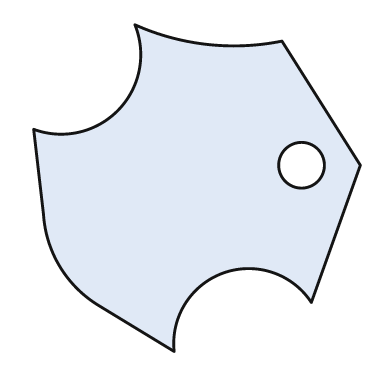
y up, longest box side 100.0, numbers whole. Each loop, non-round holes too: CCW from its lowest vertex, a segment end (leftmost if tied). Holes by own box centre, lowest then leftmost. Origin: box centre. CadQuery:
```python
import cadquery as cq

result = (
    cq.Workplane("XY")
    .moveTo(-7.0, -50.0)
    .threePointArc((8.0, -26.0), (35.0, -35.0))
    .lineTo(50.0, 7.0)
    .lineTo(26.0, 45.0)
    .threePointArc((3.0, 44.0), (-19.0, 50.0))
    .threePointArc((-24.0, 24.0), (-50.0, 18.0))
    .lineTo(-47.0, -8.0)
    .threePointArc((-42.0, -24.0), (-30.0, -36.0))
    .close()
    .moveTo(32.0, 7.0)
    .circle(7.0)
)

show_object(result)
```